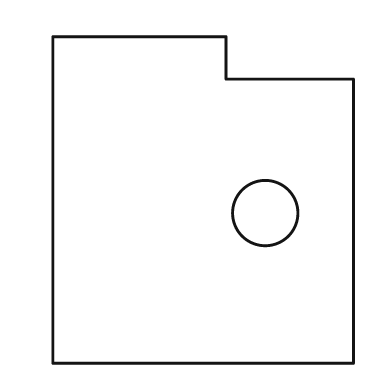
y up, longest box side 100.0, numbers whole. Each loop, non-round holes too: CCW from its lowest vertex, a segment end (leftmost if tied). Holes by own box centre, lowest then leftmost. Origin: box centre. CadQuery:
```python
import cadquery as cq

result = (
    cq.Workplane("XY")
    .moveTo(-46.0, -50.0)
    .lineTo(46.0, -50.0)
    .lineTo(46.0, 37.0)
    .lineTo(7.0, 37.0)
    .lineTo(7.0, 50.0)
    .lineTo(-46.0, 50.0)
    .close()
    .moveTo(19.0, -4.0)
    .circle(10.0)
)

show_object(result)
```